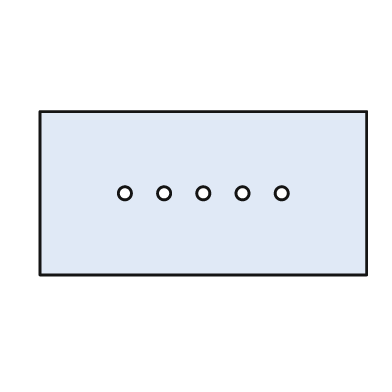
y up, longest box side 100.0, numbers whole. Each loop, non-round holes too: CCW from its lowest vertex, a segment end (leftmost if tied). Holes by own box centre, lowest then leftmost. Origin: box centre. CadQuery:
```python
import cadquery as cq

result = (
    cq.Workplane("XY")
    .moveTo(-50.0, -25.0)
    .lineTo(50.0, -25.0)
    .lineTo(50.0, 25.0)
    .lineTo(-50.0, 25.0)
    .close()
    .moveTo(-24.0, 0.0)
    .circle(2.0)
    .moveTo(-12.0, 0.0)
    .circle(2.0)
    .moveTo(0.0, 0.0)
    .circle(2.0)
    .moveTo(12.0, 0.0)
    .circle(2.0)
    .moveTo(24.0, 0.0)
    .circle(2.0)
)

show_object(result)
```